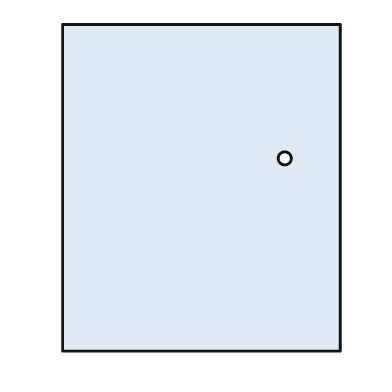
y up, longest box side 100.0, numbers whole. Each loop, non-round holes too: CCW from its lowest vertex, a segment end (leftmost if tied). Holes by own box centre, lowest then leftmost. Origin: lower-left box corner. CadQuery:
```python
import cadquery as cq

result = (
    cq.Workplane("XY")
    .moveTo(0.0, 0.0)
    .lineTo(85.0, 0.0)
    .lineTo(85.0, 100.0)
    .lineTo(0.0, 100.0)
    .close()
    .moveTo(68.0, 59.0)
    .circle(2.0)
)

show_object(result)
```